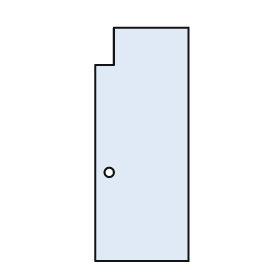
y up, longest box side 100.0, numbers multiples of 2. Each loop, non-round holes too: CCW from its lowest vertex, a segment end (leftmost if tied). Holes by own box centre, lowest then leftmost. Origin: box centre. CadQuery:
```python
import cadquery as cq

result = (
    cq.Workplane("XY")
    .moveTo(-20.0, -50.0)
    .lineTo(20.0, -50.0)
    .lineTo(20.0, 50.0)
    .lineTo(-12.0, 50.0)
    .lineTo(-12.0, 34.0)
    .lineTo(-20.0, 34.0)
    .close()
    .moveTo(-14.0, -12.0)
    .circle(2.0)
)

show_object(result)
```